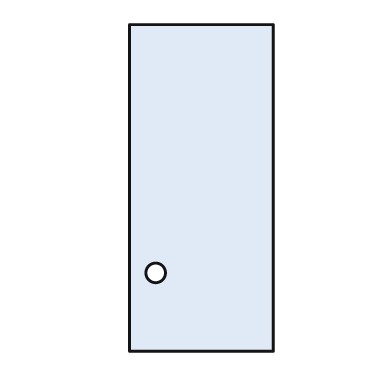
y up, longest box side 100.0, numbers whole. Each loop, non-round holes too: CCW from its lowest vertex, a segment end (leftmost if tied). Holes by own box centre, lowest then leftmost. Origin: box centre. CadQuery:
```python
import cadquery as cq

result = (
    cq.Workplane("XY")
    .moveTo(-22.0, -50.0)
    .lineTo(22.0, -50.0)
    .lineTo(22.0, 50.0)
    .lineTo(-22.0, 50.0)
    .close()
    .moveTo(-14.0, -26.0)
    .circle(3.0)
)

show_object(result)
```